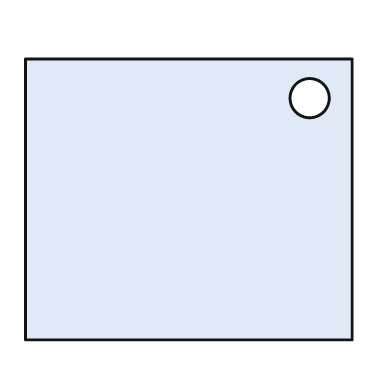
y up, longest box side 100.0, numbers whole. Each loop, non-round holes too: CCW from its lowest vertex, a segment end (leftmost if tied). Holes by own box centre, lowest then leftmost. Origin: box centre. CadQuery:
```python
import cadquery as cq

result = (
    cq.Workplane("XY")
    .moveTo(-50.0, -43.0)
    .lineTo(50.0, -43.0)
    .lineTo(50.0, 43.0)
    .lineTo(-50.0, 43.0)
    .close()
    .moveTo(37.0, 31.0)
    .circle(6.0)
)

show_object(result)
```